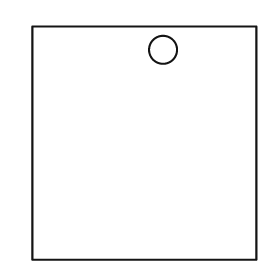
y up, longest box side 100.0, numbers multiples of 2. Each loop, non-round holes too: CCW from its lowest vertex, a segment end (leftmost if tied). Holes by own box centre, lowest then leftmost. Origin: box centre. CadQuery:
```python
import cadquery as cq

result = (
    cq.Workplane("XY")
    .moveTo(-48.0, -50.0)
    .lineTo(48.0, -50.0)
    .lineTo(48.0, 50.0)
    .lineTo(-48.0, 50.0)
    .close()
    .moveTo(8.0, 40.0)
    .circle(6.0)
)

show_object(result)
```